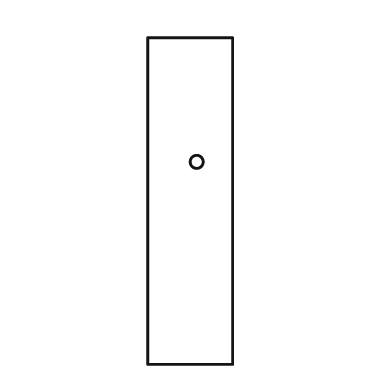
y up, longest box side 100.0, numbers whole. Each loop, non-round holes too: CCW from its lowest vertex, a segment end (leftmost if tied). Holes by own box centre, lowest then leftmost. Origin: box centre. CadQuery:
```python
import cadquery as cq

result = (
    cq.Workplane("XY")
    .moveTo(-13.0, -50.0)
    .lineTo(13.0, -50.0)
    .lineTo(13.0, 50.0)
    .lineTo(-13.0, 50.0)
    .close()
    .moveTo(2.0, 12.0)
    .circle(2.0)
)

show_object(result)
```